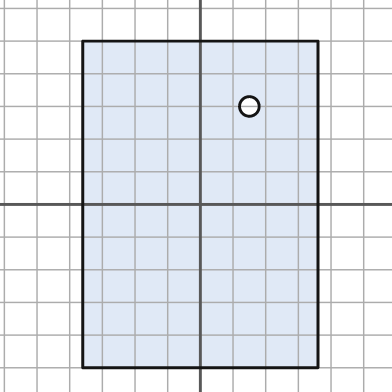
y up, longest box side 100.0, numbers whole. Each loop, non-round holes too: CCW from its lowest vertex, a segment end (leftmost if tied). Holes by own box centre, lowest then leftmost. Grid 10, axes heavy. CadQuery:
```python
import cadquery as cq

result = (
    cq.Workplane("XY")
    .moveTo(-36.0, -50.0)
    .lineTo(36.0, -50.0)
    .lineTo(36.0, 50.0)
    .lineTo(-36.0, 50.0)
    .close()
    .moveTo(15.0, 30.0)
    .circle(3.0)
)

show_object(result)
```